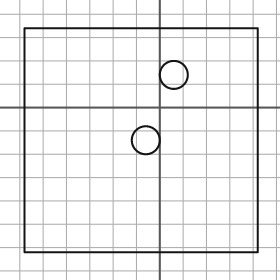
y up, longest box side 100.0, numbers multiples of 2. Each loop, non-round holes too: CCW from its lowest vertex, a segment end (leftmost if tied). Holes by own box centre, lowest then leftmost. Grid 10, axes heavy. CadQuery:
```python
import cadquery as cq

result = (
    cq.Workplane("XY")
    .moveTo(-58.0, -62.0)
    .lineTo(42.0, -62.0)
    .lineTo(42.0, 34.0)
    .lineTo(-58.0, 34.0)
    .close()
    .moveTo(-6.0, -14.0)
    .circle(6.0)
    .moveTo(6.0, 14.0)
    .circle(6.0)
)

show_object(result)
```